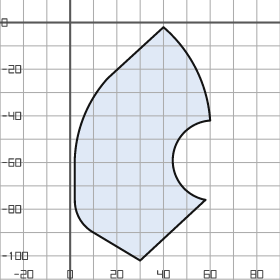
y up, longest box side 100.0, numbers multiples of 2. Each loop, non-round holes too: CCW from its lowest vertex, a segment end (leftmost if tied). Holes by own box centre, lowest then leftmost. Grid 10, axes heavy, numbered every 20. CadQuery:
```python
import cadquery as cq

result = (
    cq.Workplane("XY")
    .moveTo(30.0, -102.0)
    .lineTo(58.0, -76.0)
    .threePointArc((44.0, -58.0), (60.0, -42.0))
    .threePointArc((54.0, -20.0), (40.0, -2.0))
    .lineTo(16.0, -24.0)
    .threePointArc((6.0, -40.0), (2.0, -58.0))
    .lineTo(2.0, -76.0)
    .threePointArc((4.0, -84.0), (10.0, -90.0))
    .close()
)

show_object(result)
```